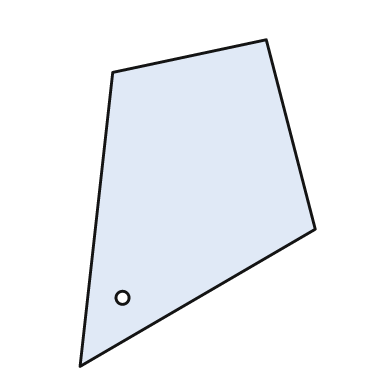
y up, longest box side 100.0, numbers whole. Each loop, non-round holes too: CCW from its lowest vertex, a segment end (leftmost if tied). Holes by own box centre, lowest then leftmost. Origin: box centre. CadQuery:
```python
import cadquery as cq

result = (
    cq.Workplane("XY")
    .moveTo(-36.0, -50.0)
    .lineTo(36.0, -8.0)
    .lineTo(21.0, 50.0)
    .lineTo(-26.0, 40.0)
    .close()
    .moveTo(-23.0, -29.0)
    .circle(2.0)
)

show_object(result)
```